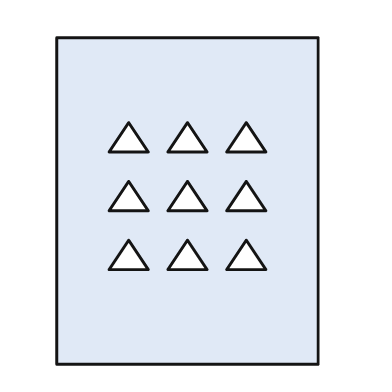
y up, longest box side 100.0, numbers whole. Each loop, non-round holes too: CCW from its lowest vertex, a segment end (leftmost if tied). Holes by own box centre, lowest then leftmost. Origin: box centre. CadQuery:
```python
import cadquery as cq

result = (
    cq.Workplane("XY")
    .moveTo(-40.0, -50.0)
    .lineTo(40.0, -50.0)
    .lineTo(40.0, 50.0)
    .lineTo(-40.0, 50.0)
    .close()
    .moveTo(-24.0, -21.0)
    .lineTo(-12.0, -21.0)
    .lineTo(-18.0, -12.0)
    .close()
    .moveTo(-6.0, -21.0)
    .lineTo(6.0, -21.0)
    .lineTo(0.0, -12.0)
    .close()
    .moveTo(12.0, -21.0)
    .lineTo(24.0, -21.0)
    .lineTo(18.0, -12.0)
    .close()
    .moveTo(-24.0, -3.0)
    .lineTo(-12.0, -3.0)
    .lineTo(-18.0, 6.0)
    .close()
    .moveTo(-6.0, -3.0)
    .lineTo(6.0, -3.0)
    .lineTo(0.0, 6.0)
    .close()
    .moveTo(12.0, -3.0)
    .lineTo(24.0, -3.0)
    .lineTo(18.0, 6.0)
    .close()
    .moveTo(-24.0, 15.0)
    .lineTo(-12.0, 15.0)
    .lineTo(-18.0, 24.0)
    .close()
    .moveTo(-6.0, 15.0)
    .lineTo(6.0, 15.0)
    .lineTo(0.0, 24.0)
    .close()
    .moveTo(12.0, 15.0)
    .lineTo(24.0, 15.0)
    .lineTo(18.0, 24.0)
    .close()
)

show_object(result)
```